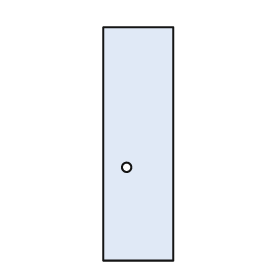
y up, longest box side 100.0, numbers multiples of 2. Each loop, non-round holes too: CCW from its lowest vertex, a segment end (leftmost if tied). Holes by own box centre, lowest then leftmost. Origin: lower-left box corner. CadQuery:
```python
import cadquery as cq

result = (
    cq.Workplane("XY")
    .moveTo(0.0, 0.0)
    .lineTo(30.0, 0.0)
    .lineTo(30.0, 100.0)
    .lineTo(0.0, 100.0)
    .close()
    .moveTo(10.0, 40.0)
    .circle(2.0)
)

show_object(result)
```